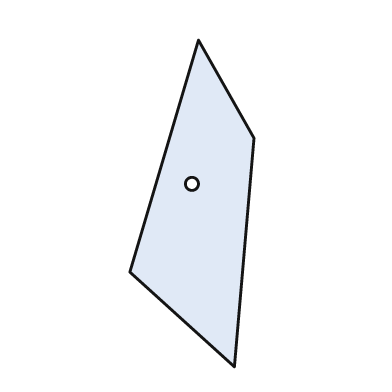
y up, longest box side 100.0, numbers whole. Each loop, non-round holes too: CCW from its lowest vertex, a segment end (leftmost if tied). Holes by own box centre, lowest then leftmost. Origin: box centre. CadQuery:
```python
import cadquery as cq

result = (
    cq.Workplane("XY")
    .moveTo(13.0, -50.0)
    .lineTo(19.0, 20.0)
    .lineTo(2.0, 50.0)
    .lineTo(-19.0, -21.0)
    .close()
    .moveTo(0.0, 6.0)
    .circle(2.0)
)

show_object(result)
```